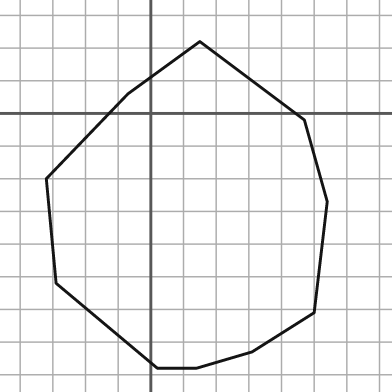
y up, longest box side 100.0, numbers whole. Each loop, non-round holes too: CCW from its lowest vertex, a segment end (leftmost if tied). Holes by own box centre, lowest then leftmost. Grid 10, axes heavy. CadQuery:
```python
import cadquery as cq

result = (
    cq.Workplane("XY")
    .moveTo(2.0, -78.0)
    .lineTo(14.0, -78.0)
    .lineTo(31.0, -73.0)
    .lineTo(50.0, -61.0)
    .lineTo(54.0, -27.0)
    .lineTo(47.0, -2.0)
    .lineTo(15.0, 22.0)
    .lineTo(-7.0, 6.0)
    .lineTo(-32.0, -20.0)
    .lineTo(-29.0, -52.0)
    .close()
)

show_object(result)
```